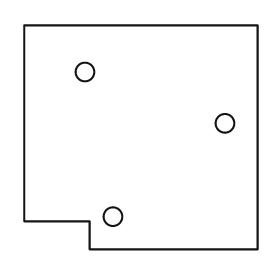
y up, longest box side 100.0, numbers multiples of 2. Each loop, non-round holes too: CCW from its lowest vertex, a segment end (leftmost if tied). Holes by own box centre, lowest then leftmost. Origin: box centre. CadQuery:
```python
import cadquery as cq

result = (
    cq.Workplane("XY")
    .moveTo(-22.0, -48.0)
    .lineTo(50.0, -48.0)
    .lineTo(50.0, 48.0)
    .lineTo(-50.0, 48.0)
    .lineTo(-50.0, -36.0)
    .lineTo(-22.0, -36.0)
    .close()
    .moveTo(-12.0, -34.0)
    .circle(4.0)
    .moveTo(36.0, 6.0)
    .circle(4.0)
    .moveTo(-24.0, 28.0)
    .circle(4.0)
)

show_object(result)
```